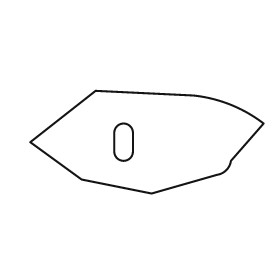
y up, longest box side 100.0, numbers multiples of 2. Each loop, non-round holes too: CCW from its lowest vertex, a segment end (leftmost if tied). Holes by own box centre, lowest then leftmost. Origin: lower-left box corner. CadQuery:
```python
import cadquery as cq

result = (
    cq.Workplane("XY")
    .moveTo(52.0, 0.0)
    .lineTo(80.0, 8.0)
    .threePointArc((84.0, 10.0), (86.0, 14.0))
    .lineTo(100.0, 30.0)
    .threePointArc((86.0, 38.0), (70.0, 42.0))
    .lineTo(28.0, 44.0)
    .lineTo(0.0, 22.0)
    .lineTo(22.0, 6.0)
    .close()
    .moveTo(36.0, 18.0)
    .threePointArc((40.0, 14.0), (44.0, 18.0))
    .lineTo(44.0, 26.0)
    .threePointArc((40.0, 30.0), (36.0, 26.0))
    .close()
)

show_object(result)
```